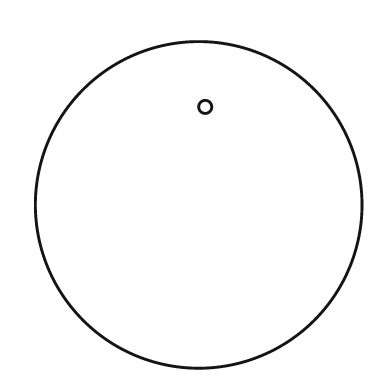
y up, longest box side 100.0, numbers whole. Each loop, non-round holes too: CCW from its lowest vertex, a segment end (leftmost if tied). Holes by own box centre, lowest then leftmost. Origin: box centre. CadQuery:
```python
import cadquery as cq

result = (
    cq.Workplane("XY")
    .moveTo(0.0, 0.0)
    .circle(50.0)
    .moveTo(2.0, 30.0)
    .circle(2.0)
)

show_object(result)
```